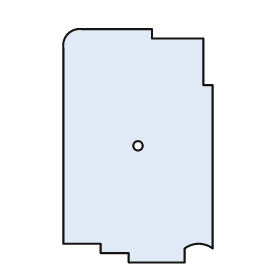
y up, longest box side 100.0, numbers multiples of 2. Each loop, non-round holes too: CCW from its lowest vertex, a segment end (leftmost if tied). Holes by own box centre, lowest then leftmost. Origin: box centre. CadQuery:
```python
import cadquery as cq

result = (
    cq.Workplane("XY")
    .moveTo(-4.0, -50.0)
    .lineTo(20.0, -50.0)
    .lineTo(20.0, -44.0)
    .threePointArc((26.0, -42.0), (32.0, -44.0))
    .lineTo(32.0, 26.0)
    .lineTo(28.0, 26.0)
    .lineTo(28.0, 46.0)
    .lineTo(6.0, 46.0)
    .lineTo(6.0, 50.0)
    .lineTo(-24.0, 50.0)
    .threePointArc((-30.0, 48.0), (-32.0, 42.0))
    .lineTo(-32.0, -42.0)
    .lineTo(-16.0, -42.0)
    .lineTo(-16.0, -46.0)
    .lineTo(-4.0, -46.0)
    .close()
    .moveTo(0.0, 0.0)
    .circle(2.0)
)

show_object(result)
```